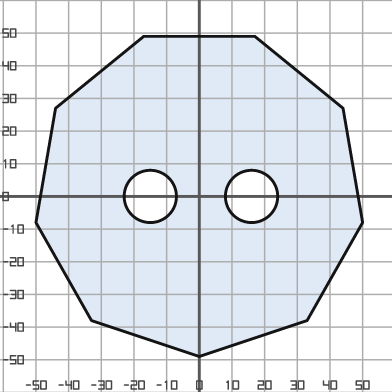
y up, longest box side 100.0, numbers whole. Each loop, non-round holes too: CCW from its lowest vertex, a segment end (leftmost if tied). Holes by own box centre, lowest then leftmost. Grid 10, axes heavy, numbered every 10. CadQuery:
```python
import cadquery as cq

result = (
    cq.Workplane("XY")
    .moveTo(0.0, -49.0)
    .lineTo(33.0, -38.0)
    .lineTo(50.0, -8.0)
    .lineTo(44.0, 27.0)
    .lineTo(17.0, 49.0)
    .lineTo(-17.0, 49.0)
    .lineTo(-44.0, 27.0)
    .lineTo(-50.0, -8.0)
    .lineTo(-33.0, -38.0)
    .close()
    .moveTo(-15.0, 0.0)
    .circle(8.0)
    .moveTo(16.0, 0.0)
    .circle(8.0)
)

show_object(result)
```